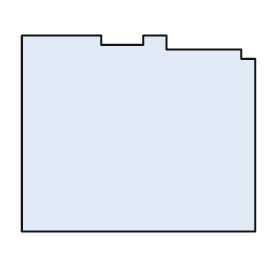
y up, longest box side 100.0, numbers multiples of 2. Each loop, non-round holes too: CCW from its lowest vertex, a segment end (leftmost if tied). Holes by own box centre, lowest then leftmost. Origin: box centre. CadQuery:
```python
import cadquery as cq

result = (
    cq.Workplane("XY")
    .moveTo(-50.0, -42.0)
    .lineTo(50.0, -42.0)
    .lineTo(50.0, 32.0)
    .lineTo(44.0, 32.0)
    .lineTo(44.0, 36.0)
    .lineTo(12.0, 36.0)
    .lineTo(12.0, 42.0)
    .lineTo(2.0, 42.0)
    .lineTo(2.0, 38.0)
    .lineTo(-16.0, 38.0)
    .lineTo(-16.0, 42.0)
    .lineTo(-50.0, 42.0)
    .close()
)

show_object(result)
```